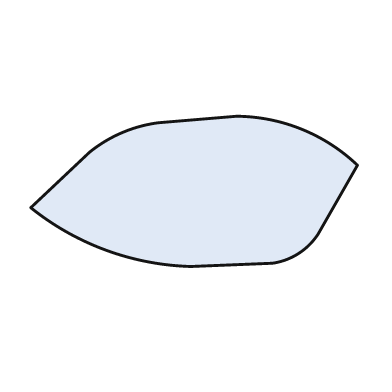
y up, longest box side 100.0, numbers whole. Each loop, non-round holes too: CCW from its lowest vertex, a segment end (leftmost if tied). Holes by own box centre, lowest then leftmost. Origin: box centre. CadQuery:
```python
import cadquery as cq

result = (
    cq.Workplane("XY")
    .moveTo(-1.0, -23.0)
    .lineTo(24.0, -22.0)
    .threePointArc((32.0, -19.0), (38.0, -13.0))
    .lineTo(50.0, 8.0)
    .threePointArc((33.0, 19.0), (13.0, 23.0))
    .lineTo(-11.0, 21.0)
    .threePointArc((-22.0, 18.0), (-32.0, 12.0))
    .lineTo(-50.0, -5.0)
    .threePointArc((-27.0, -18.0), (-1.0, -23.0))
    .close()
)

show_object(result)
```